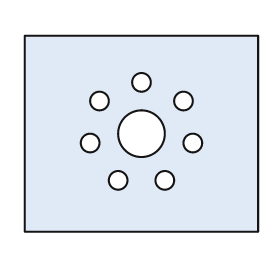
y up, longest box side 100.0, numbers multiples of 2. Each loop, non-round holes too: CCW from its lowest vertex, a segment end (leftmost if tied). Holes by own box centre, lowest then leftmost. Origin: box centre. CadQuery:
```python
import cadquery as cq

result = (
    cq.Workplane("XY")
    .moveTo(-50.0, -42.0)
    .lineTo(50.0, -42.0)
    .lineTo(50.0, 42.0)
    .lineTo(-50.0, 42.0)
    .close()
    .moveTo(-10.0, -20.0)
    .circle(4.0)
    .moveTo(10.0, -20.0)
    .circle(4.0)
    .moveTo(-22.0, -4.0)
    .circle(4.0)
    .moveTo(22.0, -4.0)
    .circle(4.0)
    .moveTo(0.0, 0.0)
    .circle(10.0)
    .moveTo(-18.0, 14.0)
    .circle(4.0)
    .moveTo(18.0, 14.0)
    .circle(4.0)
    .moveTo(0.0, 22.0)
    .circle(4.0)
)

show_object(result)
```